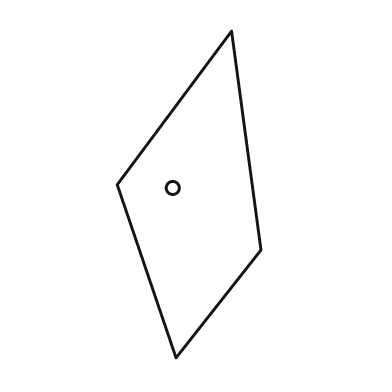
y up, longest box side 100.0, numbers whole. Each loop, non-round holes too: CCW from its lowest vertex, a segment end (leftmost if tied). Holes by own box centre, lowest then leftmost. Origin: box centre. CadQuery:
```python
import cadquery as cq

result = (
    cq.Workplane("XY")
    .moveTo(-4.0, -50.0)
    .lineTo(22.0, -17.0)
    .lineTo(13.0, 50.0)
    .lineTo(-22.0, 3.0)
    .close()
    .moveTo(-5.0, 2.0)
    .circle(2.0)
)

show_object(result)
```